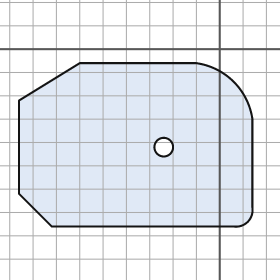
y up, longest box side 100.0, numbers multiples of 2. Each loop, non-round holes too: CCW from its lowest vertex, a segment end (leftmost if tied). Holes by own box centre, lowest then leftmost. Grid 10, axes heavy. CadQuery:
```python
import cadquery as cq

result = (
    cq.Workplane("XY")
    .moveTo(-72.0, -76.0)
    .lineTo(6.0, -76.0)
    .threePointArc((12.0, -74.0), (14.0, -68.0))
    .lineTo(14.0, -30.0)
    .threePointArc((6.0, -14.0), (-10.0, -6.0))
    .lineTo(-60.0, -6.0)
    .lineTo(-86.0, -22.0)
    .lineTo(-86.0, -62.0)
    .close()
    .moveTo(-24.0, -42.0)
    .circle(4.0)
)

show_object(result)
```